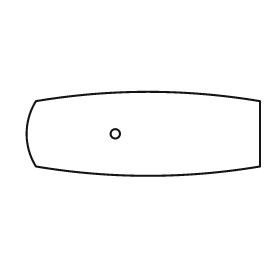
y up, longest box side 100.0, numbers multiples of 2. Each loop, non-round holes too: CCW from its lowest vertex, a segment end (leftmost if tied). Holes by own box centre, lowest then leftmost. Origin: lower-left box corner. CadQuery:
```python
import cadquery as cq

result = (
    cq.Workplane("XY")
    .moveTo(4.0, 4.0)
    .threePointArc((52.0, 0.0), (100.0, 4.0))
    .lineTo(100.0, 32.0)
    .threePointArc((52.0, 36.0), (4.0, 32.0))
    .threePointArc((0.0, 18.0), (4.0, 4.0))
    .close()
    .moveTo(38.0, 18.0)
    .circle(2.0)
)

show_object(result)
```